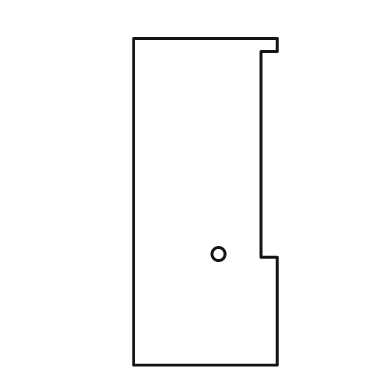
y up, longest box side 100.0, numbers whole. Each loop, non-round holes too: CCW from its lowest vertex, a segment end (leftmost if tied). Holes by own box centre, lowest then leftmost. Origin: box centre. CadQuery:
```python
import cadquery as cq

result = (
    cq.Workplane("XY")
    .moveTo(-22.0, -50.0)
    .lineTo(22.0, -50.0)
    .lineTo(22.0, -17.0)
    .lineTo(17.0, -17.0)
    .lineTo(17.0, 46.0)
    .lineTo(22.0, 46.0)
    .lineTo(22.0, 50.0)
    .lineTo(-22.0, 50.0)
    .close()
    .moveTo(4.0, -16.0)
    .circle(2.0)
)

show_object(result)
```